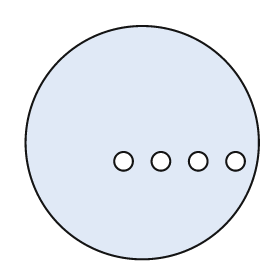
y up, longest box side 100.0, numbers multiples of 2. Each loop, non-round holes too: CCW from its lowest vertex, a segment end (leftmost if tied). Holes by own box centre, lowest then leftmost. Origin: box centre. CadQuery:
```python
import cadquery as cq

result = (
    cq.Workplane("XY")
    .moveTo(0.0, 0.0)
    .circle(50.0)
    .moveTo(-8.0, -8.0)
    .circle(4.0)
    .moveTo(8.0, -8.0)
    .circle(4.0)
    .moveTo(24.0, -8.0)
    .circle(4.0)
    .moveTo(40.0, -8.0)
    .circle(4.0)
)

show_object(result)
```